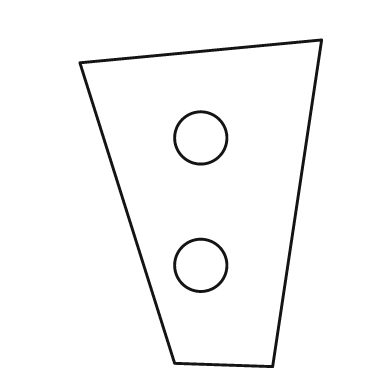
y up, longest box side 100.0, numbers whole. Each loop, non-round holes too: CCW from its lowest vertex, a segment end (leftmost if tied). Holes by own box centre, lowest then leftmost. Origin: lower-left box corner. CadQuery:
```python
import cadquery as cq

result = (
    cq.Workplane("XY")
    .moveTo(59.0, 0.0)
    .lineTo(74.0, 100.0)
    .lineTo(0.0, 93.0)
    .lineTo(29.0, 1.0)
    .close()
    .moveTo(37.0, 31.0)
    .circle(8.0)
    .moveTo(37.0, 70.0)
    .circle(8.0)
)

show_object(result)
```